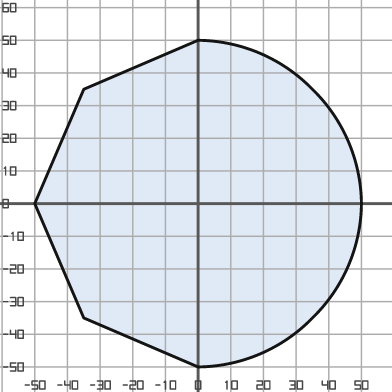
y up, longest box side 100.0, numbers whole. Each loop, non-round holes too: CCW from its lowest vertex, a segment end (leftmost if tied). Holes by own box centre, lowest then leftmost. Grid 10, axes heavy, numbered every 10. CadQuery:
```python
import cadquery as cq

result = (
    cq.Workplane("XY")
    .moveTo(0.0, -50.0)
    .threePointArc((19.0, -46.0), (35.0, -35.0))
    .threePointArc((46.0, -19.0), (50.0, 0.0))
    .threePointArc((46.0, 19.0), (35.0, 35.0))
    .threePointArc((19.0, 46.0), (0.0, 50.0))
    .lineTo(-35.0, 35.0)
    .lineTo(-50.0, 0.0)
    .lineTo(-35.0, -35.0)
    .close()
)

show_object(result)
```